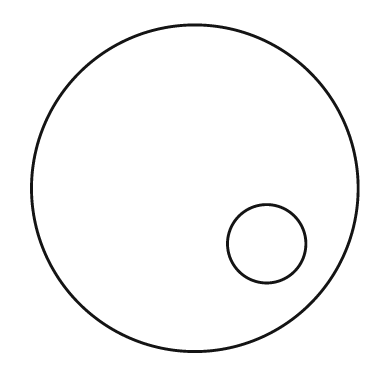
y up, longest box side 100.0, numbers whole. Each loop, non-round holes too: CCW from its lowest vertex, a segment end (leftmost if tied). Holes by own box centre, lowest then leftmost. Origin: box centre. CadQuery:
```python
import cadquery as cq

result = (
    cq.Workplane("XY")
    .moveTo(0.0, 0.0)
    .circle(50.0)
    .moveTo(22.0, -17.0)
    .circle(12.0)
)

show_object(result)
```